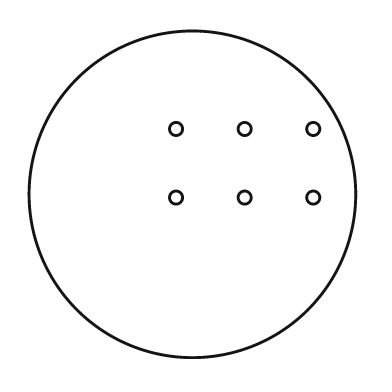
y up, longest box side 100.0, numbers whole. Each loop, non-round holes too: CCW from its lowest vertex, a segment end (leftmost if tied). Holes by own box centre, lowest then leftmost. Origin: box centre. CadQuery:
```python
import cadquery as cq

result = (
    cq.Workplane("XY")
    .moveTo(0.0, 0.0)
    .circle(50.0)
    .moveTo(-5.0, -1.0)
    .circle(2.0)
    .moveTo(16.0, -1.0)
    .circle(2.0)
    .moveTo(37.0, -1.0)
    .circle(2.0)
    .moveTo(-5.0, 20.0)
    .circle(2.0)
    .moveTo(16.0, 20.0)
    .circle(2.0)
    .moveTo(37.0, 20.0)
    .circle(2.0)
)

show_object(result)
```